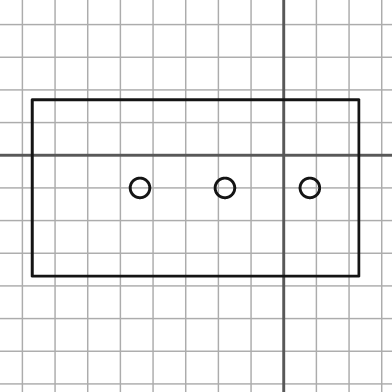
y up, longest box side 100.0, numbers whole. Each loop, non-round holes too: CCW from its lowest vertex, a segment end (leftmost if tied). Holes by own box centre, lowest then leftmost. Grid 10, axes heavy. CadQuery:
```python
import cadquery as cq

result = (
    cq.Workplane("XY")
    .moveTo(-77.0, -37.0)
    .lineTo(23.0, -37.0)
    .lineTo(23.0, 17.0)
    .lineTo(-77.0, 17.0)
    .close()
    .moveTo(-44.0, -10.0)
    .circle(3.0)
    .moveTo(-18.0, -10.0)
    .circle(3.0)
    .moveTo(8.0, -10.0)
    .circle(3.0)
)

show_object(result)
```